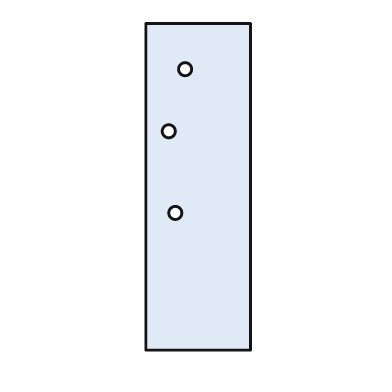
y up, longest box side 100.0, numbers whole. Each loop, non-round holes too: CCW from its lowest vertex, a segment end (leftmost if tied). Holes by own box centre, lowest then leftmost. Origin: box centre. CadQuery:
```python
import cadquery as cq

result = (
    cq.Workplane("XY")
    .moveTo(-16.0, -50.0)
    .lineTo(16.0, -50.0)
    .lineTo(16.0, 50.0)
    .lineTo(-16.0, 50.0)
    .close()
    .moveTo(-7.0, -8.0)
    .circle(2.0)
    .moveTo(-9.0, 17.0)
    .circle(2.0)
    .moveTo(-4.0, 36.0)
    .circle(2.0)
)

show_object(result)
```